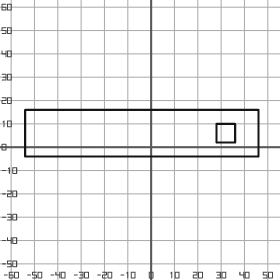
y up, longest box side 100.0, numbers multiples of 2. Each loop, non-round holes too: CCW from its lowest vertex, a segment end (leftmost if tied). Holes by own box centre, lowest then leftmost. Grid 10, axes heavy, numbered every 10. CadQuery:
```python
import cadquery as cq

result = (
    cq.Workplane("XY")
    .moveTo(-54.0, -4.0)
    .lineTo(46.0, -4.0)
    .lineTo(46.0, 16.0)
    .lineTo(-54.0, 16.0)
    .close()
    .moveTo(28.0, 2.0)
    .lineTo(36.0, 2.0)
    .lineTo(36.0, 10.0)
    .lineTo(28.0, 10.0)
    .close()
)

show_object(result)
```